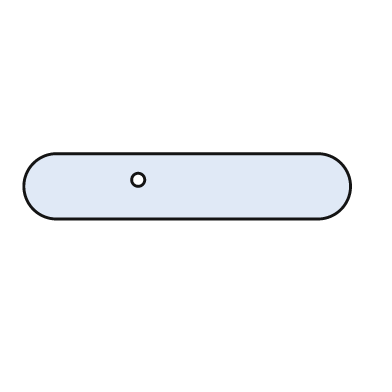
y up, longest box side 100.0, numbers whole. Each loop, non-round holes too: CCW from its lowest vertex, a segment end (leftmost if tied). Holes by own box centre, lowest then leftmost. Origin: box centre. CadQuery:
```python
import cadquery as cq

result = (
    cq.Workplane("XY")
    .moveTo(-40.0, -10.0)
    .lineTo(40.0, -10.0)
    .threePointArc((50.0, 0.0), (40.0, 10.0))
    .lineTo(-40.0, 10.0)
    .threePointArc((-50.0, 0.0), (-40.0, -10.0))
    .close()
    .moveTo(-15.0, 2.0)
    .circle(2.0)
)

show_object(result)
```